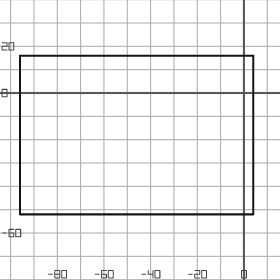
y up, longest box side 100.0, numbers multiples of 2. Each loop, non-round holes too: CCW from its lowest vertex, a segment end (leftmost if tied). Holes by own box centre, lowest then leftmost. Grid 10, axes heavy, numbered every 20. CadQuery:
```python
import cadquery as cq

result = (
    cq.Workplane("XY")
    .moveTo(-96.0, -52.0)
    .lineTo(4.0, -52.0)
    .lineTo(4.0, 16.0)
    .lineTo(-96.0, 16.0)
    .close()
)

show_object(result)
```